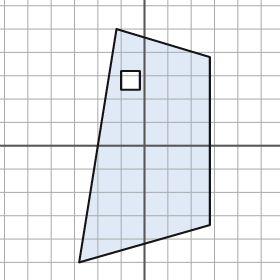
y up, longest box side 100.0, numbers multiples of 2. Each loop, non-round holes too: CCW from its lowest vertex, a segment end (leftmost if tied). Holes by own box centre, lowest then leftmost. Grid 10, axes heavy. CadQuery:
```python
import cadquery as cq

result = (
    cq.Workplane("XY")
    .moveTo(-28.0, -50.0)
    .lineTo(28.0, -34.0)
    .lineTo(28.0, 38.0)
    .lineTo(-12.0, 50.0)
    .close()
    .moveTo(-10.0, 24.0)
    .lineTo(-2.0, 24.0)
    .lineTo(-2.0, 32.0)
    .lineTo(-10.0, 32.0)
    .close()
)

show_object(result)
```